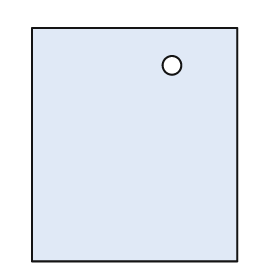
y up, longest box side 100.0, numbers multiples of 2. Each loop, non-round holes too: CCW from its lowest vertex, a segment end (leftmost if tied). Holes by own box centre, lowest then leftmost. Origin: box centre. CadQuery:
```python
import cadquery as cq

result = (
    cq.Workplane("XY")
    .moveTo(-44.0, -50.0)
    .lineTo(44.0, -50.0)
    .lineTo(44.0, 50.0)
    .lineTo(-44.0, 50.0)
    .close()
    .moveTo(16.0, 34.0)
    .circle(4.0)
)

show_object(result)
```